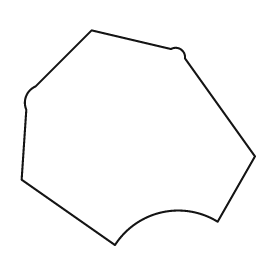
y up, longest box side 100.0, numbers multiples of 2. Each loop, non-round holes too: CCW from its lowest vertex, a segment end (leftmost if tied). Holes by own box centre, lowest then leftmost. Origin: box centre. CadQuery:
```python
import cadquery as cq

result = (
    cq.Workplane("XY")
    .moveTo(-10.0, -46.0)
    .threePointArc((10.0, -32.0), (34.0, -36.0))
    .lineTo(50.0, -8.0)
    .lineTo(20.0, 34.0)
    .threePointArc((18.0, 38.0), (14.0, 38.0))
    .lineTo(-20.0, 46.0)
    .lineTo(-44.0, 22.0)
    .threePointArc((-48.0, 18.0), (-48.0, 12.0))
    .lineTo(-50.0, -18.0)
    .close()
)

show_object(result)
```